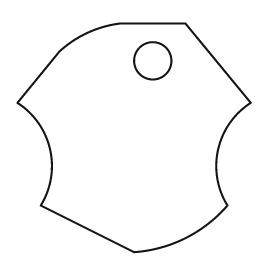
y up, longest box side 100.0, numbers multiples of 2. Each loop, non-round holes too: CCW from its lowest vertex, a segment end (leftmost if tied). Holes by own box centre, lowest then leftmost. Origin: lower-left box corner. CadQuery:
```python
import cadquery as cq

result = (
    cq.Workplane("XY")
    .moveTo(50.0, 0.0)
    .threePointArc((72.0, 6.0), (90.0, 20.0))
    .threePointArc((86.0, 44.0), (100.0, 64.0))
    .lineTo(72.0, 98.0)
    .lineTo(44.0, 98.0)
    .threePointArc((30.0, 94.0), (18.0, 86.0))
    .lineTo(0.0, 64.0)
    .threePointArc((14.0, 44.0), (10.0, 20.0))
    .close()
    .moveTo(58.0, 82.0)
    .circle(8.0)
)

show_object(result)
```